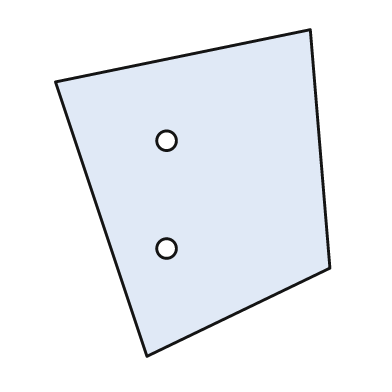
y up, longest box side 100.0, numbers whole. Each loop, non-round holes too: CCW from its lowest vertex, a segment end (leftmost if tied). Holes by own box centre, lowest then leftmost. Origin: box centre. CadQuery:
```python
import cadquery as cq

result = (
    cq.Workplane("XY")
    .moveTo(-14.0, -50.0)
    .lineTo(42.0, -23.0)
    .lineTo(36.0, 50.0)
    .lineTo(-42.0, 34.0)
    .close()
    .moveTo(-8.0, -17.0)
    .circle(3.0)
    .moveTo(-8.0, 16.0)
    .circle(3.0)
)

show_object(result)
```